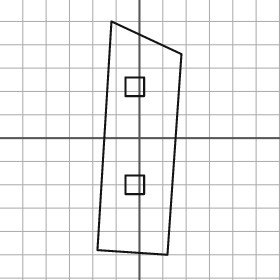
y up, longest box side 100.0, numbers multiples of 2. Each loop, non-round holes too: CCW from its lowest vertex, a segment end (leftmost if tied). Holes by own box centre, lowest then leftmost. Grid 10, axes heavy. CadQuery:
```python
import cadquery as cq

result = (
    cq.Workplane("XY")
    .moveTo(12.0, -50.0)
    .lineTo(18.0, 36.0)
    .lineTo(-12.0, 50.0)
    .lineTo(-18.0, -48.0)
    .close()
    .moveTo(-6.0, -24.0)
    .lineTo(2.0, -24.0)
    .lineTo(2.0, -16.0)
    .lineTo(-6.0, -16.0)
    .close()
    .moveTo(-6.0, 18.0)
    .lineTo(2.0, 18.0)
    .lineTo(2.0, 26.0)
    .lineTo(-6.0, 26.0)
    .close()
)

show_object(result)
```